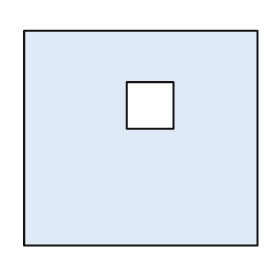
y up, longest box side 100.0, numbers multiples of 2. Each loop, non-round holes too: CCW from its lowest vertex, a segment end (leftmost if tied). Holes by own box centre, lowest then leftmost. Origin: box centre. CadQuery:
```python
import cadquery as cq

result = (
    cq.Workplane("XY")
    .moveTo(-50.0, -46.0)
    .lineTo(50.0, -46.0)
    .lineTo(50.0, 46.0)
    .lineTo(-50.0, 46.0)
    .close()
    .moveTo(-6.0, 4.0)
    .lineTo(14.0, 4.0)
    .lineTo(14.0, 24.0)
    .lineTo(-6.0, 24.0)
    .close()
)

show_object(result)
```